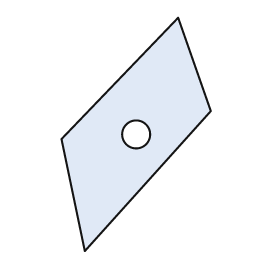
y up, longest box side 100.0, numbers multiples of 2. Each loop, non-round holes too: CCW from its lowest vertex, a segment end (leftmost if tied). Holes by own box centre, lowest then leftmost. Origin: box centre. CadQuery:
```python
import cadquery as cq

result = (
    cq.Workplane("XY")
    .moveTo(-22.0, -50.0)
    .lineTo(32.0, 10.0)
    .lineTo(18.0, 50.0)
    .lineTo(-32.0, -2.0)
    .close()
    .moveTo(0.0, 0.0)
    .circle(6.0)
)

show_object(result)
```